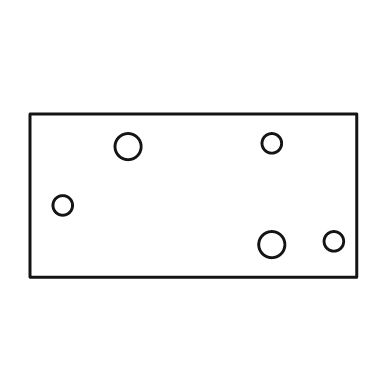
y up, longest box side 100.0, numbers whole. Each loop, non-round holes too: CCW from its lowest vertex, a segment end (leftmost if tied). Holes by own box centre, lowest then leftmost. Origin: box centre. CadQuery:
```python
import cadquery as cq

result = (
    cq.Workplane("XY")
    .moveTo(-50.0, -25.0)
    .lineTo(50.0, -25.0)
    .lineTo(50.0, 25.0)
    .lineTo(-50.0, 25.0)
    .close()
    .moveTo(24.0, -15.0)
    .circle(4.0)
    .moveTo(43.0, -14.0)
    .circle(3.0)
    .moveTo(-40.0, -3.0)
    .circle(3.0)
    .moveTo(-20.0, 15.0)
    .circle(4.0)
    .moveTo(24.0, 16.0)
    .circle(3.0)
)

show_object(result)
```